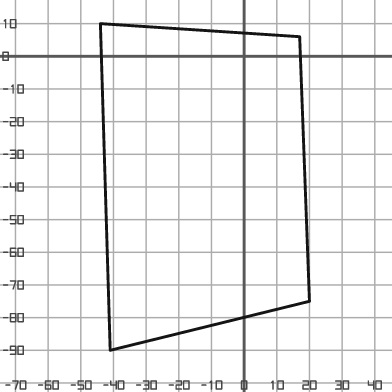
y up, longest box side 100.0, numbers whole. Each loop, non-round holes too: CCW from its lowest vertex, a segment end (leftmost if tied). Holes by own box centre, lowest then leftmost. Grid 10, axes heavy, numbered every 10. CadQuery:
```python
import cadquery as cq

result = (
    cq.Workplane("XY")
    .moveTo(-41.0, -90.0)
    .lineTo(20.0, -75.0)
    .lineTo(17.0, 6.0)
    .lineTo(-44.0, 10.0)
    .close()
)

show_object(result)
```